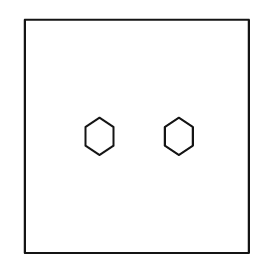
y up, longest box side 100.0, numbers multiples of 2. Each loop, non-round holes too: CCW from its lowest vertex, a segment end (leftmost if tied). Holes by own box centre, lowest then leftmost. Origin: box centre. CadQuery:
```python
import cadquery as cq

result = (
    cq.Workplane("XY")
    .moveTo(-48.0, -50.0)
    .lineTo(48.0, -50.0)
    .lineTo(48.0, 50.0)
    .lineTo(-48.0, 50.0)
    .close()
    .moveTo(-16.0, -8.0)
    .lineTo(-10.0, -4.0)
    .lineTo(-10.0, 4.0)
    .lineTo(-16.0, 8.0)
    .lineTo(-22.0, 4.0)
    .lineTo(-22.0, -4.0)
    .close()
    .moveTo(18.0, -8.0)
    .lineTo(24.0, -4.0)
    .lineTo(24.0, 4.0)
    .lineTo(18.0, 8.0)
    .lineTo(12.0, 4.0)
    .lineTo(12.0, -4.0)
    .close()
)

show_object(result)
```